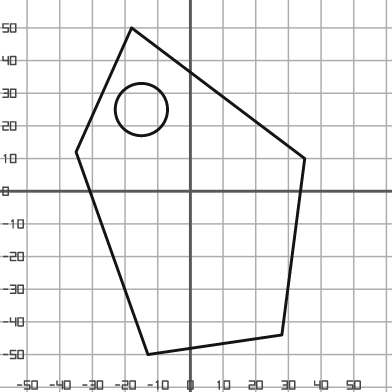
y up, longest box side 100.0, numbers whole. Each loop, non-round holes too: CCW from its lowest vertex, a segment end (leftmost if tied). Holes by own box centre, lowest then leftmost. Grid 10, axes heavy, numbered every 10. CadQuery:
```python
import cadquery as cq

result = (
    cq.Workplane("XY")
    .moveTo(-13.0, -50.0)
    .lineTo(28.0, -44.0)
    .lineTo(35.0, 10.0)
    .lineTo(-18.0, 50.0)
    .lineTo(-35.0, 12.0)
    .close()
    .moveTo(-15.0, 25.0)
    .circle(8.0)
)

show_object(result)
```